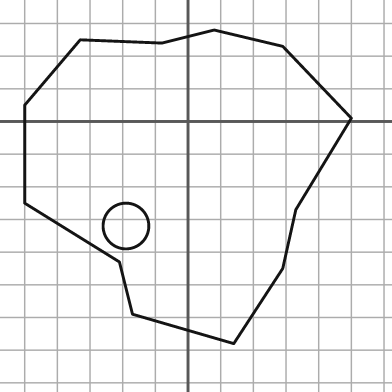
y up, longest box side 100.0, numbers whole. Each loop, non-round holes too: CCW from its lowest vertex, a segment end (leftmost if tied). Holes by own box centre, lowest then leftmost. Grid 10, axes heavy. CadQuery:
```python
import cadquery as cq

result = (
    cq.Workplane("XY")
    .moveTo(14.0, -68.0)
    .lineTo(29.0, -45.0)
    .lineTo(33.0, -27.0)
    .lineTo(50.0, 1.0)
    .lineTo(29.0, 23.0)
    .lineTo(8.0, 28.0)
    .lineTo(-8.0, 24.0)
    .lineTo(-33.0, 25.0)
    .lineTo(-50.0, 5.0)
    .lineTo(-50.0, -25.0)
    .lineTo(-21.0, -43.0)
    .lineTo(-17.0, -59.0)
    .close()
    .moveTo(-19.0, -32.0)
    .circle(7.0)
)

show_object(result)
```